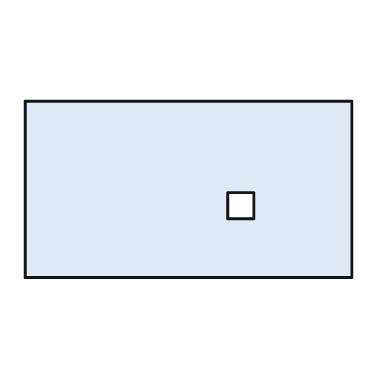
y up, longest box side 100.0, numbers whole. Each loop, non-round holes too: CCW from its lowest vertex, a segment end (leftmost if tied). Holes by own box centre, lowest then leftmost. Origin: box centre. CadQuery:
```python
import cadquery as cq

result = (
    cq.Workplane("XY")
    .moveTo(-50.0, -27.0)
    .lineTo(50.0, -27.0)
    .lineTo(50.0, 27.0)
    .lineTo(-50.0, 27.0)
    .close()
    .moveTo(12.0, -9.0)
    .lineTo(20.0, -9.0)
    .lineTo(20.0, -1.0)
    .lineTo(12.0, -1.0)
    .close()
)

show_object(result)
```